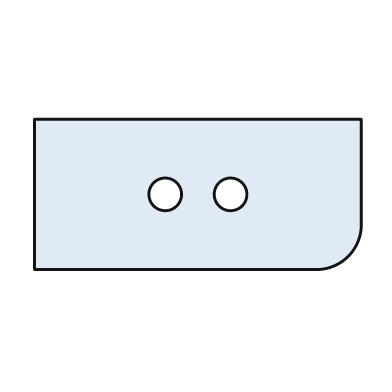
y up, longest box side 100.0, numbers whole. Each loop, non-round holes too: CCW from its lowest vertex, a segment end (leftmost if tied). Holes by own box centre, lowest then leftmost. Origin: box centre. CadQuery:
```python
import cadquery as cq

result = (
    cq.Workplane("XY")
    .moveTo(-50.0, -23.0)
    .lineTo(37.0, -23.0)
    .threePointArc((46.0, -19.0), (50.0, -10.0))
    .lineTo(50.0, 23.0)
    .lineTo(-50.0, 23.0)
    .close()
    .moveTo(-10.0, 0.0)
    .circle(5.0)
    .moveTo(10.0, 0.0)
    .circle(5.0)
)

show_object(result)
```